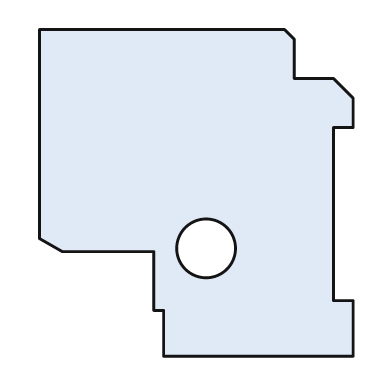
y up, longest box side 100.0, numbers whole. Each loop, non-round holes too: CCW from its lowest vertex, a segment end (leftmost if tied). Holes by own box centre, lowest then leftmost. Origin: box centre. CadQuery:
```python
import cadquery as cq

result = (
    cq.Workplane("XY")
    .moveTo(-10.0, -50.0)
    .lineTo(48.0, -50.0)
    .lineTo(48.0, -33.0)
    .lineTo(42.0, -33.0)
    .lineTo(42.0, 20.0)
    .lineTo(48.0, 20.0)
    .lineTo(48.0, 29.0)
    .lineTo(42.0, 35.0)
    .lineTo(30.0, 35.0)
    .lineTo(30.0, 47.0)
    .lineTo(27.0, 50.0)
    .lineTo(-48.0, 50.0)
    .lineTo(-48.0, -14.0)
    .lineTo(-41.0, -18.0)
    .lineTo(-13.0, -18.0)
    .lineTo(-13.0, -36.0)
    .lineTo(-10.0, -36.0)
    .close()
    .moveTo(3.0, -17.0)
    .circle(9.0)
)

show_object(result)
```